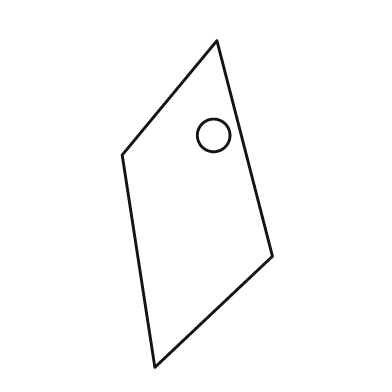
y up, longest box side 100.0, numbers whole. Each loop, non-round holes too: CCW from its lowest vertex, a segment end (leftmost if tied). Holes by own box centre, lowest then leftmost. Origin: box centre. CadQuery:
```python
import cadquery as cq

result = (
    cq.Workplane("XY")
    .moveTo(-13.0, -50.0)
    .lineTo(23.0, -16.0)
    .lineTo(6.0, 50.0)
    .lineTo(-23.0, 15.0)
    .close()
    .moveTo(5.0, 21.0)
    .circle(5.0)
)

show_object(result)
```